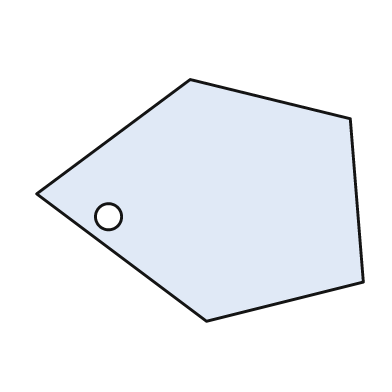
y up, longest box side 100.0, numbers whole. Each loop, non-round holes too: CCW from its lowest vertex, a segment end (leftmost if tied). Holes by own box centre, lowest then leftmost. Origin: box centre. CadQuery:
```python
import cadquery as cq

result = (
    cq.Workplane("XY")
    .moveTo(2.0, -37.0)
    .lineTo(50.0, -25.0)
    .lineTo(46.0, 25.0)
    .lineTo(-3.0, 37.0)
    .lineTo(-50.0, 2.0)
    .close()
    .moveTo(-28.0, -5.0)
    .circle(4.0)
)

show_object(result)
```